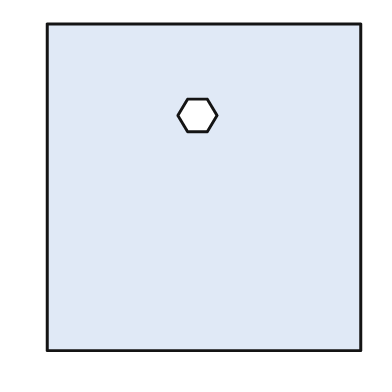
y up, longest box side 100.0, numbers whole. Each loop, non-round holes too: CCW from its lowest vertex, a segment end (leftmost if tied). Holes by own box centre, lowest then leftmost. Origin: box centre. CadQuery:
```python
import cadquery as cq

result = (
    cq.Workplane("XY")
    .moveTo(-48.0, -50.0)
    .lineTo(48.0, -50.0)
    .lineTo(48.0, 50.0)
    .lineTo(-48.0, 50.0)
    .close()
    .moveTo(-5.0, 17.0)
    .lineTo(1.0, 17.0)
    .lineTo(4.0, 22.0)
    .lineTo(1.0, 27.0)
    .lineTo(-5.0, 27.0)
    .lineTo(-8.0, 22.0)
    .close()
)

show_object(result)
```